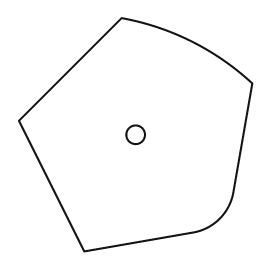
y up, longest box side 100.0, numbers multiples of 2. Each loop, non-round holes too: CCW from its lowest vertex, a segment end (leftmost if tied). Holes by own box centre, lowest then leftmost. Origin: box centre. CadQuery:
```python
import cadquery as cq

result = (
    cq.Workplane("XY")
    .moveTo(-22.0, -50.0)
    .lineTo(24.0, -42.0)
    .threePointArc((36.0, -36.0), (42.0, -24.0))
    .lineTo(50.0, 22.0)
    .threePointArc((24.0, 40.0), (-6.0, 50.0))
    .lineTo(-50.0, 6.0)
    .close()
    .moveTo(0.0, 0.0)
    .circle(4.0)
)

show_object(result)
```